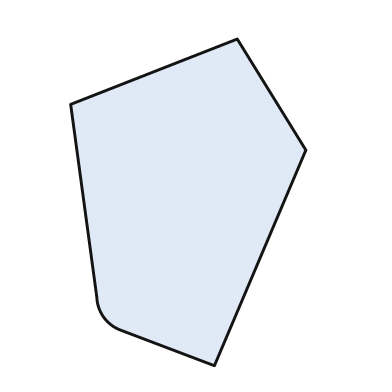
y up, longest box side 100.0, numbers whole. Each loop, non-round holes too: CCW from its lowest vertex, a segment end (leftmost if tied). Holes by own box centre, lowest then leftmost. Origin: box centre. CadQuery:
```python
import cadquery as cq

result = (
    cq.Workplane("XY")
    .moveTo(8.0, -50.0)
    .lineTo(36.0, 16.0)
    .lineTo(15.0, 50.0)
    .lineTo(-36.0, 30.0)
    .lineTo(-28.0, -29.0)
    .threePointArc((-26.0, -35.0), (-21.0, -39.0))
    .close()
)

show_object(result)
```